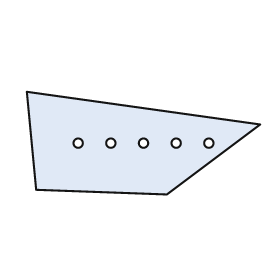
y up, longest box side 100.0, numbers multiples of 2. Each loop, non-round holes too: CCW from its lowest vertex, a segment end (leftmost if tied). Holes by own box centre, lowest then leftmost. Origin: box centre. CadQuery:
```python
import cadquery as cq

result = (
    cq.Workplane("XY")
    .moveTo(10.0, -22.0)
    .lineTo(50.0, 8.0)
    .lineTo(-50.0, 22.0)
    .lineTo(-46.0, -20.0)
    .close()
    .moveTo(-28.0, 0.0)
    .circle(2.0)
    .moveTo(-14.0, 0.0)
    .circle(2.0)
    .moveTo(0.0, 0.0)
    .circle(2.0)
    .moveTo(14.0, 0.0)
    .circle(2.0)
    .moveTo(28.0, 0.0)
    .circle(2.0)
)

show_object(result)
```